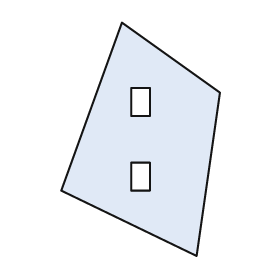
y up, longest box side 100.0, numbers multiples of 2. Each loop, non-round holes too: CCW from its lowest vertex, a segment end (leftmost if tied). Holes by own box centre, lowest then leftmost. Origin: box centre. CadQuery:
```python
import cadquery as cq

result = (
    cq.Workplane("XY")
    .moveTo(24.0, -50.0)
    .lineTo(34.0, 20.0)
    .lineTo(-8.0, 50.0)
    .lineTo(-34.0, -22.0)
    .close()
    .moveTo(-4.0, -22.0)
    .lineTo(4.0, -22.0)
    .lineTo(4.0, -10.0)
    .lineTo(-4.0, -10.0)
    .close()
    .moveTo(-4.0, 10.0)
    .lineTo(4.0, 10.0)
    .lineTo(4.0, 22.0)
    .lineTo(-4.0, 22.0)
    .close()
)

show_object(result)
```